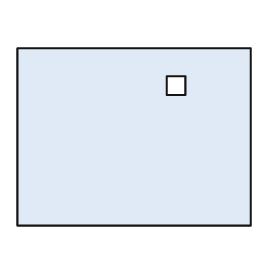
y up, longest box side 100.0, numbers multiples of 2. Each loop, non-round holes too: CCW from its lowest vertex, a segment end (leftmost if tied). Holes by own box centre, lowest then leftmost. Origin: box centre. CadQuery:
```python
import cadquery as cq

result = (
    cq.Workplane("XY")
    .moveTo(-50.0, -38.0)
    .lineTo(50.0, -38.0)
    .lineTo(50.0, 38.0)
    .lineTo(-50.0, 38.0)
    .close()
    .moveTo(14.0, 18.0)
    .lineTo(22.0, 18.0)
    .lineTo(22.0, 26.0)
    .lineTo(14.0, 26.0)
    .close()
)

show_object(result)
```